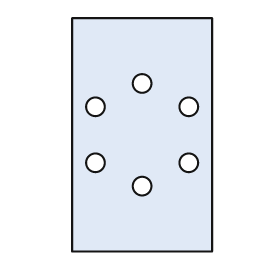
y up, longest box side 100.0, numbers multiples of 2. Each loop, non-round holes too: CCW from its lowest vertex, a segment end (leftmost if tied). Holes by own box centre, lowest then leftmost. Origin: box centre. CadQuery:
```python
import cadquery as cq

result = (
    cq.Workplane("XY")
    .moveTo(-30.0, -50.0)
    .lineTo(30.0, -50.0)
    .lineTo(30.0, 50.0)
    .lineTo(-30.0, 50.0)
    .close()
    .moveTo(0.0, -22.0)
    .circle(4.0)
    .moveTo(-20.0, -12.0)
    .circle(4.0)
    .moveTo(20.0, -12.0)
    .circle(4.0)
    .moveTo(-20.0, 12.0)
    .circle(4.0)
    .moveTo(20.0, 12.0)
    .circle(4.0)
    .moveTo(0.0, 22.0)
    .circle(4.0)
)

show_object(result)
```